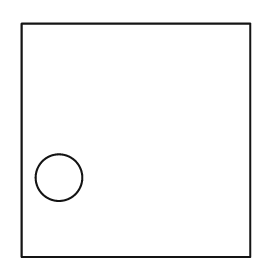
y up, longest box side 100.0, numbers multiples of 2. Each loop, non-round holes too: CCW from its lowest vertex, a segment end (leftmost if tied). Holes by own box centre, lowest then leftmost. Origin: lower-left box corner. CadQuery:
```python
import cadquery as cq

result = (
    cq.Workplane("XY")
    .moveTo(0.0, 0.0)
    .lineTo(98.0, 0.0)
    .lineTo(98.0, 100.0)
    .lineTo(0.0, 100.0)
    .close()
    .moveTo(16.0, 34.0)
    .circle(10.0)
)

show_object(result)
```